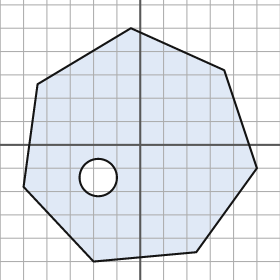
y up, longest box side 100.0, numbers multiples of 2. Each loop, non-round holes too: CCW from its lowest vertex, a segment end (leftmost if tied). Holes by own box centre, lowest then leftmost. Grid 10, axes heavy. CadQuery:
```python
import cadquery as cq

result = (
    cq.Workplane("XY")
    .moveTo(-20.0, -50.0)
    .lineTo(24.0, -46.0)
    .lineTo(50.0, -10.0)
    .lineTo(36.0, 32.0)
    .lineTo(-4.0, 50.0)
    .lineTo(-44.0, 26.0)
    .lineTo(-50.0, -18.0)
    .close()
    .moveTo(-18.0, -14.0)
    .circle(8.0)
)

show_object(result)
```